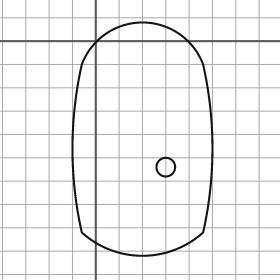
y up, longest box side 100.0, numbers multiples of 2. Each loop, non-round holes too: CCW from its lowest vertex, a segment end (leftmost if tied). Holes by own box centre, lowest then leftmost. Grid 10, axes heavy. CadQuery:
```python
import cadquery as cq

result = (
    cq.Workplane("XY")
    .moveTo(-6.0, -82.0)
    .threePointArc((20.0, -92.0), (46.0, -82.0))
    .threePointArc((50.0, -46.0), (46.0, -10.0))
    .threePointArc((20.0, 8.0), (-6.0, -10.0))
    .threePointArc((-10.0, -46.0), (-6.0, -82.0))
    .close()
    .moveTo(30.0, -54.0)
    .circle(4.0)
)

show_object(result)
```